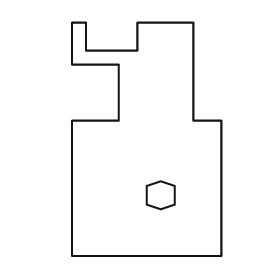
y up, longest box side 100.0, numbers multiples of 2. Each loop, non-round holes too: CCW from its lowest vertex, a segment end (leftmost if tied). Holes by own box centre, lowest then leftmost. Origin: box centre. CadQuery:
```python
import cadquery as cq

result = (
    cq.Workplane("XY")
    .moveTo(-32.0, -50.0)
    .lineTo(32.0, -50.0)
    .lineTo(32.0, 8.0)
    .lineTo(20.0, 8.0)
    .lineTo(20.0, 50.0)
    .lineTo(-4.0, 50.0)
    .lineTo(-4.0, 38.0)
    .lineTo(-26.0, 38.0)
    .lineTo(-26.0, 50.0)
    .lineTo(-32.0, 50.0)
    .lineTo(-32.0, 32.0)
    .lineTo(-12.0, 32.0)
    .lineTo(-12.0, 8.0)
    .lineTo(-32.0, 8.0)
    .close()
    .moveTo(6.0, -30.0)
    .lineTo(12.0, -28.0)
    .lineTo(12.0, -20.0)
    .lineTo(6.0, -18.0)
    .lineTo(0.0, -20.0)
    .lineTo(0.0, -28.0)
    .close()
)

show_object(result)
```